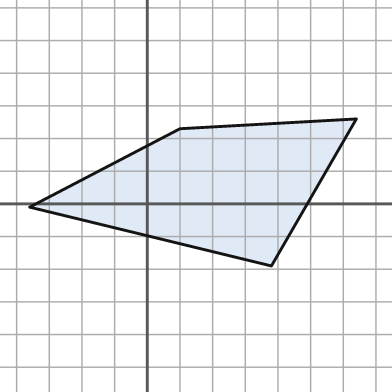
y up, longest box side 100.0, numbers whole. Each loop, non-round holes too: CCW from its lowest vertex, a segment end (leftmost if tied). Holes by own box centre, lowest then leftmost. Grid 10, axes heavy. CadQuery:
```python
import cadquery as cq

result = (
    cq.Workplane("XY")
    .moveTo(38.0, -19.0)
    .lineTo(64.0, 26.0)
    .lineTo(10.0, 23.0)
    .lineTo(-36.0, -1.0)
    .close()
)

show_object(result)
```